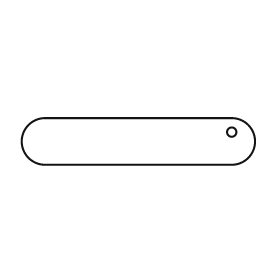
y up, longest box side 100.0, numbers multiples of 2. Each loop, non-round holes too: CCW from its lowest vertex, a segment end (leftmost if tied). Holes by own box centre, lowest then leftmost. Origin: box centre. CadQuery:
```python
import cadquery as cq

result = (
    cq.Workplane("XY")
    .moveTo(-40.0, -10.0)
    .lineTo(40.0, -10.0)
    .threePointArc((50.0, 0.0), (40.0, 10.0))
    .lineTo(-40.0, 10.0)
    .threePointArc((-50.0, 0.0), (-40.0, -10.0))
    .close()
    .moveTo(40.0, 4.0)
    .circle(2.0)
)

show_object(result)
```